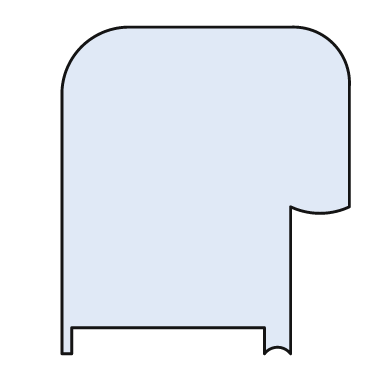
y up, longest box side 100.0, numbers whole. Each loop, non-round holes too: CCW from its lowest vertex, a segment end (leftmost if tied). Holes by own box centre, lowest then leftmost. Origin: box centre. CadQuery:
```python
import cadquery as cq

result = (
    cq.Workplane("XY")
    .moveTo(-44.0, -50.0)
    .lineTo(-41.0, -50.0)
    .lineTo(-41.0, -42.0)
    .lineTo(18.0, -42.0)
    .lineTo(18.0, -50.0)
    .threePointArc((22.0, -48.0), (26.0, -50.0))
    .lineTo(26.0, -5.0)
    .threePointArc((35.0, -7.0), (44.0, -5.0))
    .lineTo(44.0, 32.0)
    .threePointArc((39.0, 45.0), (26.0, 50.0))
    .lineTo(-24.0, 50.0)
    .threePointArc((-38.0, 44.0), (-44.0, 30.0))
    .close()
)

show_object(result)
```